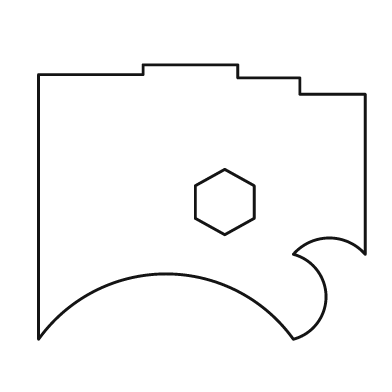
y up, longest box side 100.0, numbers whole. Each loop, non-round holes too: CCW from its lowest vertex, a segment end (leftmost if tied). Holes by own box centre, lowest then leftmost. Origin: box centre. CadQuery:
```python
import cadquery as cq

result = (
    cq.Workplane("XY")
    .moveTo(-50.0, -42.0)
    .threePointArc((-11.0, -22.0), (28.0, -42.0))
    .threePointArc((38.0, -29.0), (28.0, -16.0))
    .threePointArc((39.0, -11.0), (50.0, -16.0))
    .lineTo(50.0, 33.0)
    .lineTo(30.0, 33.0)
    .lineTo(30.0, 38.0)
    .lineTo(11.0, 38.0)
    .lineTo(11.0, 42.0)
    .lineTo(-18.0, 42.0)
    .lineTo(-18.0, 39.0)
    .lineTo(-50.0, 39.0)
    .close()
    .moveTo(7.0, -10.0)
    .lineTo(16.0, -5.0)
    .lineTo(16.0, 5.0)
    .lineTo(7.0, 10.0)
    .lineTo(-2.0, 5.0)
    .lineTo(-2.0, -5.0)
    .close()
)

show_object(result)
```